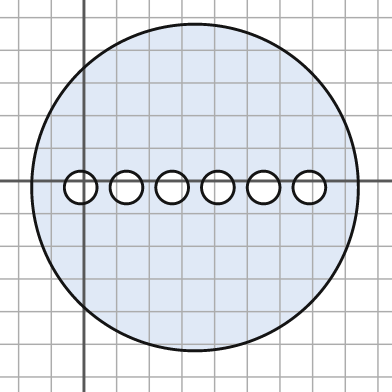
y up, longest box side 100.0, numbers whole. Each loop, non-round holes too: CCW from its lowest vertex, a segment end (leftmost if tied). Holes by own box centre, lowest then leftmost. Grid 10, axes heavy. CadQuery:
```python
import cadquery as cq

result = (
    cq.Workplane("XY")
    .moveTo(34.0, -2.0)
    .circle(50.0)
    .moveTo(-1.0, -2.0)
    .circle(5.0)
    .moveTo(13.0, -2.0)
    .circle(5.0)
    .moveTo(27.0, -2.0)
    .circle(5.0)
    .moveTo(41.0, -2.0)
    .circle(5.0)
    .moveTo(55.0, -2.0)
    .circle(5.0)
    .moveTo(69.0, -2.0)
    .circle(5.0)
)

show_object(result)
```